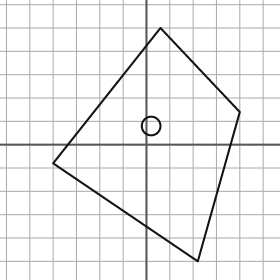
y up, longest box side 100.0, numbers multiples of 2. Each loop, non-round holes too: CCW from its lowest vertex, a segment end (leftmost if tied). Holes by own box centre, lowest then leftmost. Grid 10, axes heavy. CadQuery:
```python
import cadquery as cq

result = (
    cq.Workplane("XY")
    .moveTo(22.0, -50.0)
    .lineTo(40.0, 14.0)
    .lineTo(6.0, 50.0)
    .lineTo(-40.0, -8.0)
    .close()
    .moveTo(2.0, 8.0)
    .circle(4.0)
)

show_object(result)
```